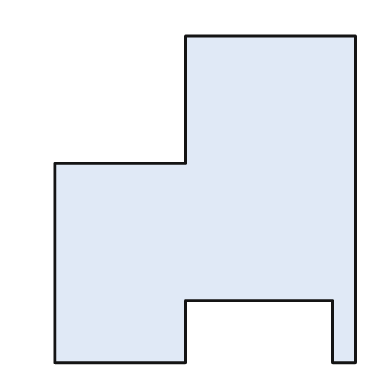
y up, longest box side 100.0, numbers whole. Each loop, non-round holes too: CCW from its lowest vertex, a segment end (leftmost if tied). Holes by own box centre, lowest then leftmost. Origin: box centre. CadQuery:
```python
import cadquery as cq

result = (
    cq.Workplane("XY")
    .moveTo(-46.0, -50.0)
    .lineTo(-6.0, -50.0)
    .lineTo(-6.0, -31.0)
    .lineTo(39.0, -31.0)
    .lineTo(39.0, -50.0)
    .lineTo(46.0, -50.0)
    .lineTo(46.0, 50.0)
    .lineTo(-6.0, 50.0)
    .lineTo(-6.0, 11.0)
    .lineTo(-46.0, 11.0)
    .close()
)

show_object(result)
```